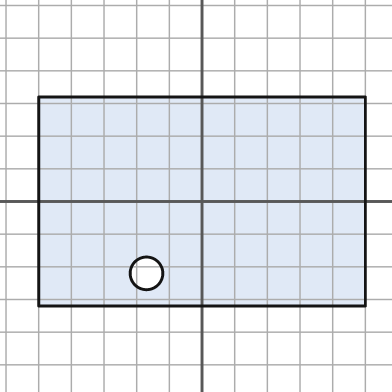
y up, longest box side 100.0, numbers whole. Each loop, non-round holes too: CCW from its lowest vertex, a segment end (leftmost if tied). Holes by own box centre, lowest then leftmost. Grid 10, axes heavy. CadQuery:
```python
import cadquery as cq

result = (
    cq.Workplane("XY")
    .moveTo(-50.0, -32.0)
    .lineTo(50.0, -32.0)
    .lineTo(50.0, 32.0)
    .lineTo(-50.0, 32.0)
    .close()
    .moveTo(-17.0, -22.0)
    .circle(5.0)
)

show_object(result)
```